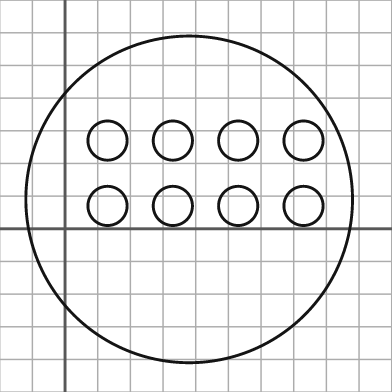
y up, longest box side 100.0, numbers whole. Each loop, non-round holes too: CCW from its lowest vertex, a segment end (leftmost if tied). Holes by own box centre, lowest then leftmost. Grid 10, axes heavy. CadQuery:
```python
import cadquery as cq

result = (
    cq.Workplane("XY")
    .moveTo(38.0, 9.0)
    .circle(50.0)
    .moveTo(13.0, 7.0)
    .circle(6.0)
    .moveTo(33.0, 7.0)
    .circle(6.0)
    .moveTo(53.0, 7.0)
    .circle(6.0)
    .moveTo(73.0, 7.0)
    .circle(6.0)
    .moveTo(13.0, 27.0)
    .circle(6.0)
    .moveTo(33.0, 27.0)
    .circle(6.0)
    .moveTo(53.0, 27.0)
    .circle(6.0)
    .moveTo(73.0, 27.0)
    .circle(6.0)
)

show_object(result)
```